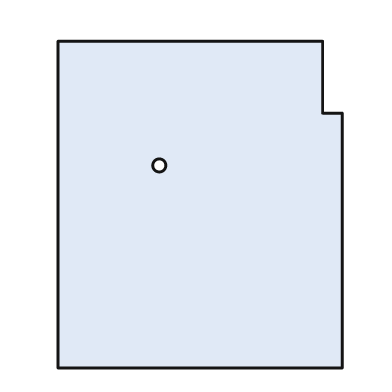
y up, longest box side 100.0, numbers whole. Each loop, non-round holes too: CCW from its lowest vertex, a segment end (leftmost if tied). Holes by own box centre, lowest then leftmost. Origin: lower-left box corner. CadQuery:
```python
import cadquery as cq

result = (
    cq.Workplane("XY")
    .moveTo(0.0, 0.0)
    .lineTo(87.0, 0.0)
    .lineTo(87.0, 78.0)
    .lineTo(81.0, 78.0)
    .lineTo(81.0, 100.0)
    .lineTo(0.0, 100.0)
    .close()
    .moveTo(31.0, 62.0)
    .circle(2.0)
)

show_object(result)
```